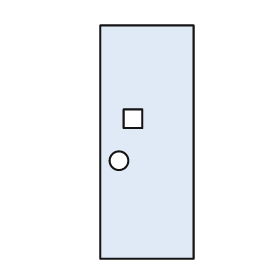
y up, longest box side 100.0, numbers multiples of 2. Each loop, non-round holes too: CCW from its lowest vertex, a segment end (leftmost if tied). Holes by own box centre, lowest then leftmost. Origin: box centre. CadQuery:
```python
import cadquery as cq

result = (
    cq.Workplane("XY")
    .moveTo(-20.0, -50.0)
    .lineTo(20.0, -50.0)
    .lineTo(20.0, 50.0)
    .lineTo(-20.0, 50.0)
    .close()
    .moveTo(-12.0, -8.0)
    .circle(4.0)
    .moveTo(-10.0, 6.0)
    .lineTo(-2.0, 6.0)
    .lineTo(-2.0, 14.0)
    .lineTo(-10.0, 14.0)
    .close()
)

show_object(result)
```